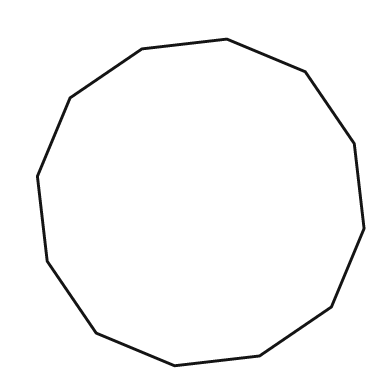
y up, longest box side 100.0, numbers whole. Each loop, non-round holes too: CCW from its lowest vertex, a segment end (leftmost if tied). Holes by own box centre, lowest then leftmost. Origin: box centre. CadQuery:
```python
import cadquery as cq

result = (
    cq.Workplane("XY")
    .moveTo(-8.0, -50.0)
    .lineTo(18.0, -47.0)
    .lineTo(40.0, -32.0)
    .lineTo(50.0, -8.0)
    .lineTo(47.0, 18.0)
    .lineTo(32.0, 40.0)
    .lineTo(8.0, 50.0)
    .lineTo(-18.0, 47.0)
    .lineTo(-40.0, 32.0)
    .lineTo(-50.0, 8.0)
    .lineTo(-47.0, -18.0)
    .lineTo(-32.0, -40.0)
    .close()
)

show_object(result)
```